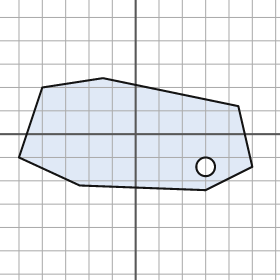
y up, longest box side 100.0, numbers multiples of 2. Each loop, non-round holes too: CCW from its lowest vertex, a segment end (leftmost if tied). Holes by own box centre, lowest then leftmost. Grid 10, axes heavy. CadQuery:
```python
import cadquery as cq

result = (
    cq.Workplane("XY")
    .moveTo(30.0, -24.0)
    .lineTo(50.0, -14.0)
    .lineTo(44.0, 12.0)
    .lineTo(-14.0, 24.0)
    .lineTo(-40.0, 20.0)
    .lineTo(-50.0, -10.0)
    .lineTo(-24.0, -22.0)
    .close()
    .moveTo(30.0, -14.0)
    .circle(4.0)
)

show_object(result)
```